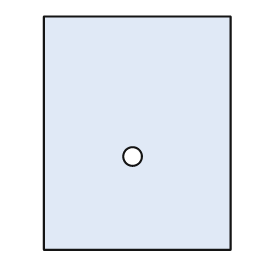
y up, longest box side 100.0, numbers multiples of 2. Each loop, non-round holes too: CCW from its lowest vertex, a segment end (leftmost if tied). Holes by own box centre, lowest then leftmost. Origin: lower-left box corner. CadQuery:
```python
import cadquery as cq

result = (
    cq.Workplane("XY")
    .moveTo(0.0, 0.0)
    .lineTo(80.0, 0.0)
    .lineTo(80.0, 100.0)
    .lineTo(0.0, 100.0)
    .close()
    .moveTo(38.0, 40.0)
    .circle(4.0)
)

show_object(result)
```